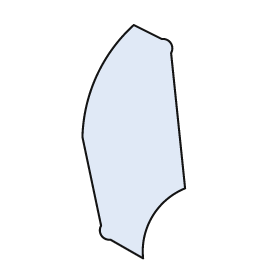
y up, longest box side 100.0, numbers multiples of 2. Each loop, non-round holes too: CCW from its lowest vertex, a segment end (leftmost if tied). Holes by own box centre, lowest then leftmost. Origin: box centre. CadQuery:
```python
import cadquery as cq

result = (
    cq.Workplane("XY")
    .moveTo(4.0, -50.0)
    .threePointArc((8.0, -32.0), (22.0, -20.0))
    .lineTo(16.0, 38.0)
    .threePointArc((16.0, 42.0), (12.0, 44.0))
    .lineTo(0.0, 50.0)
    .threePointArc((-16.0, 28.0), (-22.0, 2.0))
    .lineTo(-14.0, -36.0)
    .threePointArc((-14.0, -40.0), (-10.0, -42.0))
    .close()
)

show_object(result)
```